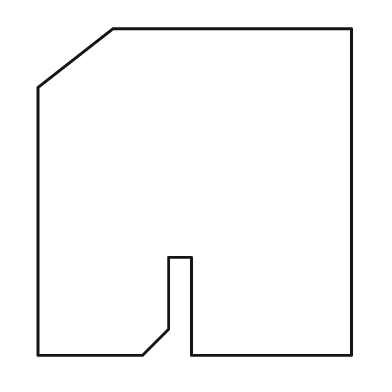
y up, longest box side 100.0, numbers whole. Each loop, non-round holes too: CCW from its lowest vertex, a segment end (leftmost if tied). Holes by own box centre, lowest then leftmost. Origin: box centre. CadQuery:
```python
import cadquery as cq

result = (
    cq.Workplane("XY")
    .moveTo(-48.0, -50.0)
    .lineTo(-16.0, -50.0)
    .lineTo(-8.0, -42.0)
    .lineTo(-8.0, -20.0)
    .lineTo(-1.0, -20.0)
    .lineTo(-1.0, -50.0)
    .lineTo(48.0, -50.0)
    .lineTo(48.0, 50.0)
    .lineTo(-25.0, 50.0)
    .lineTo(-48.0, 32.0)
    .close()
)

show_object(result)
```